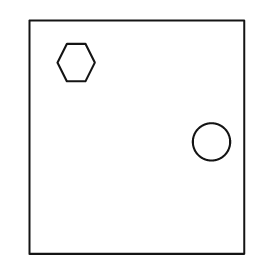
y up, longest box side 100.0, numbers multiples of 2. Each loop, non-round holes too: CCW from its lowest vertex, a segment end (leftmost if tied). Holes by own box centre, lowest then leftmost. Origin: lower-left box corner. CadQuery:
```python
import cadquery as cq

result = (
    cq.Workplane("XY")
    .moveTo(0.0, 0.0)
    .lineTo(92.0, 0.0)
    .lineTo(92.0, 100.0)
    .lineTo(0.0, 100.0)
    .close()
    .moveTo(78.0, 48.0)
    .circle(8.0)
    .moveTo(16.0, 74.0)
    .lineTo(24.0, 74.0)
    .lineTo(28.0, 82.0)
    .lineTo(24.0, 90.0)
    .lineTo(16.0, 90.0)
    .lineTo(12.0, 82.0)
    .close()
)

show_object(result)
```